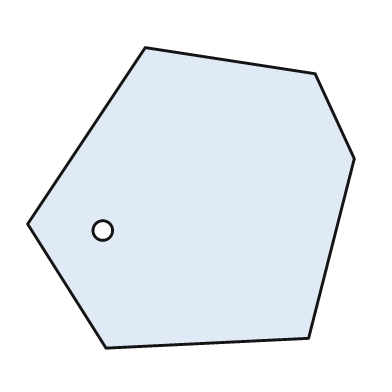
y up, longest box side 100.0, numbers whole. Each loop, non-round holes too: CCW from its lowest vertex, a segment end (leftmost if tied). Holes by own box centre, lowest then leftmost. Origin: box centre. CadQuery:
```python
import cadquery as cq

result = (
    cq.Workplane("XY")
    .moveTo(-26.0, -46.0)
    .lineTo(36.0, -43.0)
    .lineTo(50.0, 12.0)
    .lineTo(38.0, 38.0)
    .lineTo(-14.0, 46.0)
    .lineTo(-50.0, -8.0)
    .close()
    .moveTo(-27.0, -10.0)
    .circle(3.0)
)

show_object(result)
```